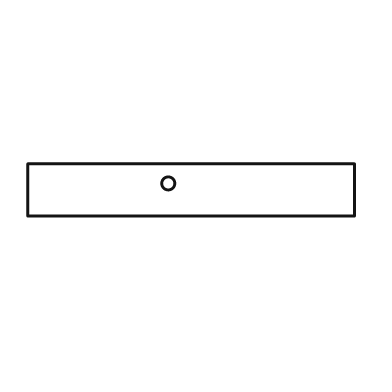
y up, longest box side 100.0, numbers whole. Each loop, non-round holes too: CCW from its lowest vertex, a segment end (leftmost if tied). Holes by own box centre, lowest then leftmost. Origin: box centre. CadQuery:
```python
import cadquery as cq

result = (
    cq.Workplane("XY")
    .moveTo(-50.0, -8.0)
    .lineTo(50.0, -8.0)
    .lineTo(50.0, 8.0)
    .lineTo(-50.0, 8.0)
    .close()
    .moveTo(-7.0, 2.0)
    .circle(2.0)
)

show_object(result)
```